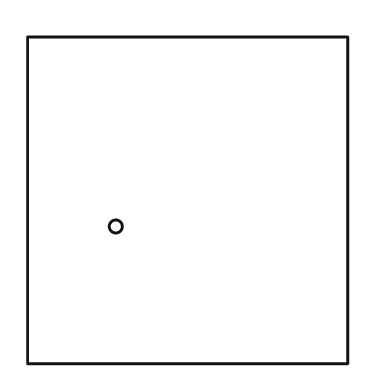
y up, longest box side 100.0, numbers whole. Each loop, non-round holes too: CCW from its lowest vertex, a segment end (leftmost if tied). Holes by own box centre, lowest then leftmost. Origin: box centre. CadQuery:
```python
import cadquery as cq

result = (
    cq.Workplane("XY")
    .moveTo(-49.0, -50.0)
    .lineTo(49.0, -50.0)
    .lineTo(49.0, 50.0)
    .lineTo(-49.0, 50.0)
    .close()
    .moveTo(-22.0, -8.0)
    .circle(2.0)
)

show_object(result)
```